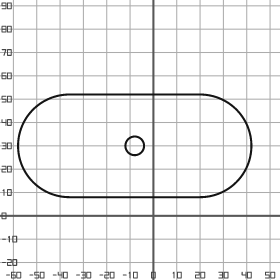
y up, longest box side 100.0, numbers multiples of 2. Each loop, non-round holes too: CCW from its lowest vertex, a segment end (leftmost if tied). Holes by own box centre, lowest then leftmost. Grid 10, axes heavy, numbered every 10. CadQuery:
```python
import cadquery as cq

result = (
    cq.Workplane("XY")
    .moveTo(-36.0, 8.0)
    .lineTo(20.0, 8.0)
    .threePointArc((42.0, 30.0), (20.0, 52.0))
    .lineTo(-36.0, 52.0)
    .threePointArc((-58.0, 30.0), (-36.0, 8.0))
    .close()
    .moveTo(-8.0, 30.0)
    .circle(4.0)
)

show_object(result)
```